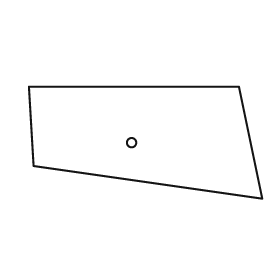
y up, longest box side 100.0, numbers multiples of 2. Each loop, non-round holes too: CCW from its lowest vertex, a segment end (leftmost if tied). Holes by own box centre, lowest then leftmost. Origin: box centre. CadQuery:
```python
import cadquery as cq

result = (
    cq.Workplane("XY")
    .moveTo(50.0, -24.0)
    .lineTo(40.0, 24.0)
    .lineTo(-50.0, 24.0)
    .lineTo(-48.0, -10.0)
    .close()
    .moveTo(-6.0, 0.0)
    .circle(2.0)
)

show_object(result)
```